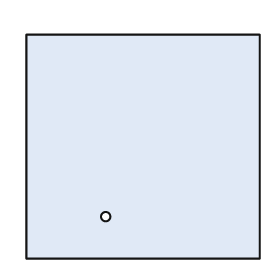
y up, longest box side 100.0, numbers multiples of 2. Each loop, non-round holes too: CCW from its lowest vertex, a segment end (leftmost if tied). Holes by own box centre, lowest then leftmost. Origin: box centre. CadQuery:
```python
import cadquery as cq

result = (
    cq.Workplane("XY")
    .moveTo(-50.0, -48.0)
    .lineTo(50.0, -48.0)
    .lineTo(50.0, 48.0)
    .lineTo(-50.0, 48.0)
    .close()
    .moveTo(-16.0, -30.0)
    .circle(2.0)
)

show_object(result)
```